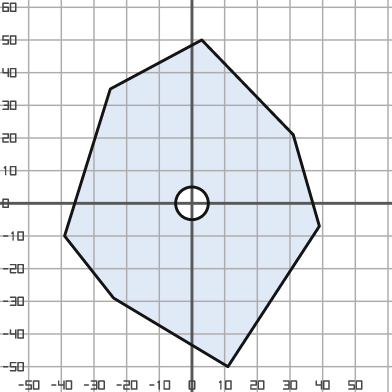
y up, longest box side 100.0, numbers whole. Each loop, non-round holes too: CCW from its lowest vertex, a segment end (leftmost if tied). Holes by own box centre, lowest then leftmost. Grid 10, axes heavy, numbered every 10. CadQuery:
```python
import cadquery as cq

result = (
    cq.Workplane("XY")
    .moveTo(11.0, -50.0)
    .lineTo(39.0, -7.0)
    .lineTo(31.0, 21.0)
    .lineTo(3.0, 50.0)
    .lineTo(-25.0, 35.0)
    .lineTo(-39.0, -10.0)
    .lineTo(-24.0, -29.0)
    .close()
    .moveTo(0.0, 0.0)
    .circle(5.0)
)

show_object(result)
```